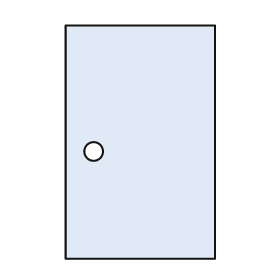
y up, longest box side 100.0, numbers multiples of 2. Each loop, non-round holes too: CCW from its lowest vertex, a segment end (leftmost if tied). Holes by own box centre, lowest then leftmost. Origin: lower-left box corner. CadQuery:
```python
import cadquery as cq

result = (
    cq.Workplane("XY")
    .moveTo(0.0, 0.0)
    .lineTo(64.0, 0.0)
    .lineTo(64.0, 100.0)
    .lineTo(0.0, 100.0)
    .close()
    .moveTo(12.0, 46.0)
    .circle(4.0)
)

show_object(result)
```